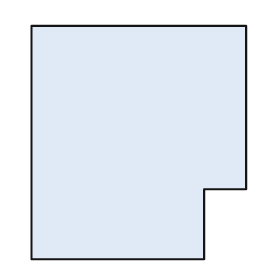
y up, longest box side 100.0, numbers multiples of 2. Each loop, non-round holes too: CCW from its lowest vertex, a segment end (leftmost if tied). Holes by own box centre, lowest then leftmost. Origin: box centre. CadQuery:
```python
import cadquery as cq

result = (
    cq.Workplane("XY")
    .moveTo(-46.0, -50.0)
    .lineTo(28.0, -50.0)
    .lineTo(28.0, -20.0)
    .lineTo(46.0, -20.0)
    .lineTo(46.0, 50.0)
    .lineTo(-46.0, 50.0)
    .close()
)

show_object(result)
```